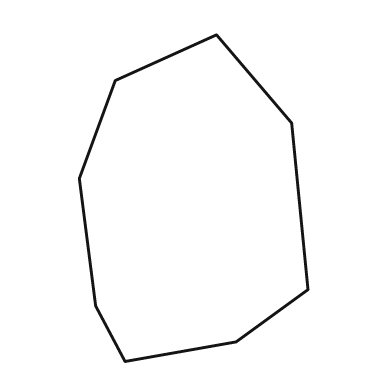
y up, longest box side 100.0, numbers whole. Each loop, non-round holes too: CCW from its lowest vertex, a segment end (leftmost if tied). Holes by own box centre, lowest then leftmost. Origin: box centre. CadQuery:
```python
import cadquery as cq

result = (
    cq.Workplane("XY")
    .moveTo(-21.0, -50.0)
    .lineTo(13.0, -44.0)
    .lineTo(35.0, -28.0)
    .lineTo(30.0, 23.0)
    .lineTo(7.0, 50.0)
    .lineTo(-24.0, 36.0)
    .lineTo(-35.0, 6.0)
    .lineTo(-30.0, -33.0)
    .close()
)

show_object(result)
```